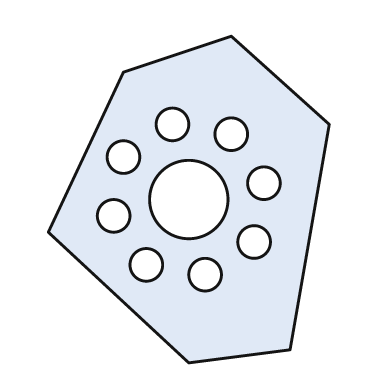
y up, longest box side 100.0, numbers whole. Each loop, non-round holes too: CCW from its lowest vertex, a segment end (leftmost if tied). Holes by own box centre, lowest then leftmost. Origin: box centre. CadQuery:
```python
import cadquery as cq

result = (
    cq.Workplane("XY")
    .moveTo(0.0, -50.0)
    .lineTo(31.0, -46.0)
    .lineTo(43.0, 23.0)
    .lineTo(13.0, 50.0)
    .lineTo(-20.0, 39.0)
    .lineTo(-43.0, -10.0)
    .close()
    .moveTo(5.0, -23.0)
    .circle(5.0)
    .moveTo(-13.0, -20.0)
    .circle(5.0)
    .moveTo(20.0, -13.0)
    .circle(5.0)
    .moveTo(-23.0, -5.0)
    .circle(5.0)
    .moveTo(0.0, 0.0)
    .circle(12.0)
    .moveTo(23.0, 5.0)
    .circle(5.0)
    .moveTo(-20.0, 13.0)
    .circle(5.0)
    .moveTo(13.0, 20.0)
    .circle(5.0)
    .moveTo(-5.0, 23.0)
    .circle(5.0)
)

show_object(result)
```